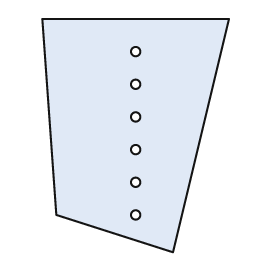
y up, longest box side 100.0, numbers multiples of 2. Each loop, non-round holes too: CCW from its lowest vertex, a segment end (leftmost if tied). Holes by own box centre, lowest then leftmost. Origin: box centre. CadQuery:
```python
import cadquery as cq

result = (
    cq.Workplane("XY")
    .moveTo(16.0, -50.0)
    .lineTo(40.0, 50.0)
    .lineTo(-40.0, 50.0)
    .lineTo(-34.0, -34.0)
    .close()
    .moveTo(0.0, -34.0)
    .circle(2.0)
    .moveTo(0.0, -20.0)
    .circle(2.0)
    .moveTo(0.0, -6.0)
    .circle(2.0)
    .moveTo(0.0, 8.0)
    .circle(2.0)
    .moveTo(0.0, 22.0)
    .circle(2.0)
    .moveTo(0.0, 36.0)
    .circle(2.0)
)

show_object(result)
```